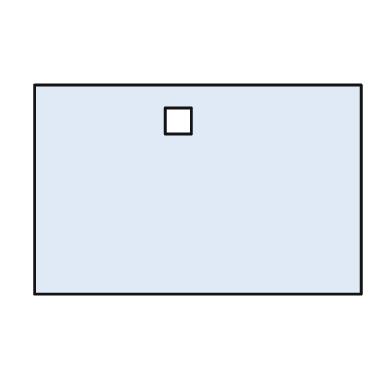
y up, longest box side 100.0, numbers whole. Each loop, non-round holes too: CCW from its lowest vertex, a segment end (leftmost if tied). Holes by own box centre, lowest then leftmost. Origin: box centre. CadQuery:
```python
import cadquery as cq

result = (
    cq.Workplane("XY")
    .moveTo(-50.0, -32.0)
    .lineTo(50.0, -32.0)
    .lineTo(50.0, 32.0)
    .lineTo(-50.0, 32.0)
    .close()
    .moveTo(-10.0, 17.0)
    .lineTo(-2.0, 17.0)
    .lineTo(-2.0, 25.0)
    .lineTo(-10.0, 25.0)
    .close()
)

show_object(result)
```